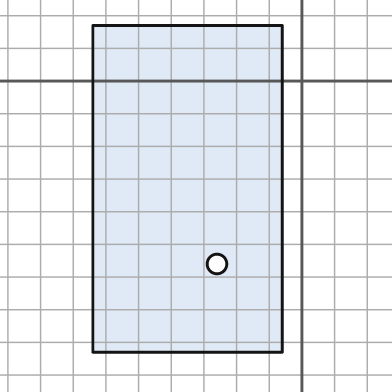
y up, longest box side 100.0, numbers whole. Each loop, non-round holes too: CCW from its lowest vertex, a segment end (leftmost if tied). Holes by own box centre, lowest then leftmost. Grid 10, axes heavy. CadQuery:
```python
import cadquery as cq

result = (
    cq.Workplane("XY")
    .moveTo(-64.0, -83.0)
    .lineTo(-6.0, -83.0)
    .lineTo(-6.0, 17.0)
    .lineTo(-64.0, 17.0)
    .close()
    .moveTo(-26.0, -56.0)
    .circle(3.0)
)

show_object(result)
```